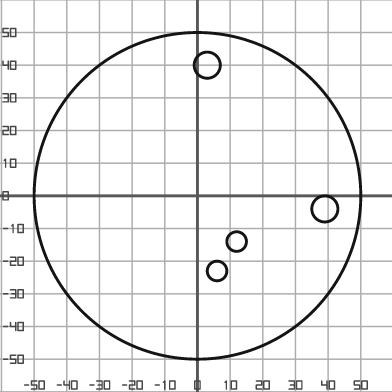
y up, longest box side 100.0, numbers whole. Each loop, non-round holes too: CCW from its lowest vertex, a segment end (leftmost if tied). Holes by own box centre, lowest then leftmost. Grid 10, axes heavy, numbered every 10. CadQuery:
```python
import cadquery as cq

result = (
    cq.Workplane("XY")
    .moveTo(0.0, 0.0)
    .circle(50.0)
    .moveTo(6.0, -23.0)
    .circle(3.0)
    .moveTo(12.0, -14.0)
    .circle(3.0)
    .moveTo(39.0, -4.0)
    .circle(4.0)
    .moveTo(3.0, 40.0)
    .circle(4.0)
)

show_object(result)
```